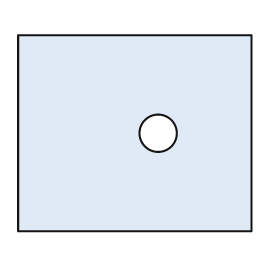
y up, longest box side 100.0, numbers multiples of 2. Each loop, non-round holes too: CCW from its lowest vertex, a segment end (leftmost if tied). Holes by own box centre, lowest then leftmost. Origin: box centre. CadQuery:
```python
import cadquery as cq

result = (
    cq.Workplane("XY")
    .moveTo(-50.0, -42.0)
    .lineTo(50.0, -42.0)
    .lineTo(50.0, 42.0)
    .lineTo(-50.0, 42.0)
    .close()
    .moveTo(10.0, 0.0)
    .circle(8.0)
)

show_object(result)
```